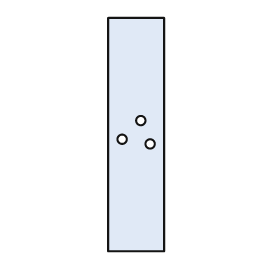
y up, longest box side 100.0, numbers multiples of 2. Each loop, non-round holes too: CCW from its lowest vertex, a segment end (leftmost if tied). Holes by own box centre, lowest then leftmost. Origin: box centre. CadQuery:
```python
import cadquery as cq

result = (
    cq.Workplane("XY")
    .moveTo(-12.0, -50.0)
    .lineTo(12.0, -50.0)
    .lineTo(12.0, 50.0)
    .lineTo(-12.0, 50.0)
    .close()
    .moveTo(6.0, -4.0)
    .circle(2.0)
    .moveTo(-6.0, -2.0)
    .circle(2.0)
    .moveTo(2.0, 6.0)
    .circle(2.0)
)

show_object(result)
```